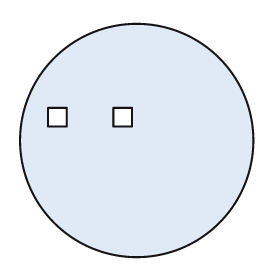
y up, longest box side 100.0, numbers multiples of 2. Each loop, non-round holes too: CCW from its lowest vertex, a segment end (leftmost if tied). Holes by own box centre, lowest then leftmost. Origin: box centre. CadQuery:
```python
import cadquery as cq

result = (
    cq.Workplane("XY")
    .moveTo(0.0, 0.0)
    .circle(50.0)
    .moveTo(-38.0, 6.0)
    .lineTo(-30.0, 6.0)
    .lineTo(-30.0, 14.0)
    .lineTo(-38.0, 14.0)
    .close()
    .moveTo(-10.0, 6.0)
    .lineTo(-2.0, 6.0)
    .lineTo(-2.0, 14.0)
    .lineTo(-10.0, 14.0)
    .close()
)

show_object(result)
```